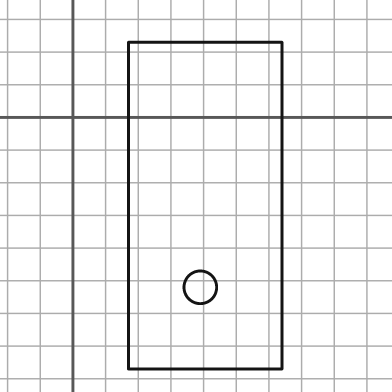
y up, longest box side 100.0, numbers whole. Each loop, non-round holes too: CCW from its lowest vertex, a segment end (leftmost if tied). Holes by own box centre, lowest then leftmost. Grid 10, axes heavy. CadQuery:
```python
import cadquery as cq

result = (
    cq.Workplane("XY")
    .moveTo(17.0, -77.0)
    .lineTo(64.0, -77.0)
    .lineTo(64.0, 23.0)
    .lineTo(17.0, 23.0)
    .close()
    .moveTo(39.0, -52.0)
    .circle(5.0)
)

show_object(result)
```